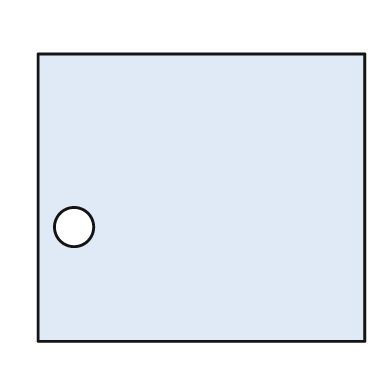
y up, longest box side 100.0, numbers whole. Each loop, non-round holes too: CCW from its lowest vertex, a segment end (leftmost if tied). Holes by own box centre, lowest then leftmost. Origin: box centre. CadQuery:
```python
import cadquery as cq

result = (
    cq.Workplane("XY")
    .moveTo(-50.0, -44.0)
    .lineTo(50.0, -44.0)
    .lineTo(50.0, 44.0)
    .lineTo(-50.0, 44.0)
    .close()
    .moveTo(-39.0, -9.0)
    .circle(6.0)
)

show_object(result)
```